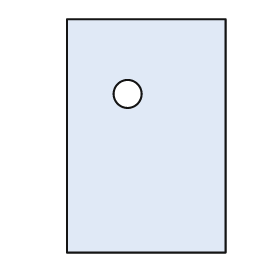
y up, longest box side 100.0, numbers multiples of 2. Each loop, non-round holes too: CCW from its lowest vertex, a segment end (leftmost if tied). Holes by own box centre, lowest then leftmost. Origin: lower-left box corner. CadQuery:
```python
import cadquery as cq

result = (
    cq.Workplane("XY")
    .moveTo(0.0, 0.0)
    .lineTo(68.0, 0.0)
    .lineTo(68.0, 100.0)
    .lineTo(0.0, 100.0)
    .close()
    .moveTo(26.0, 68.0)
    .circle(6.0)
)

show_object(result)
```